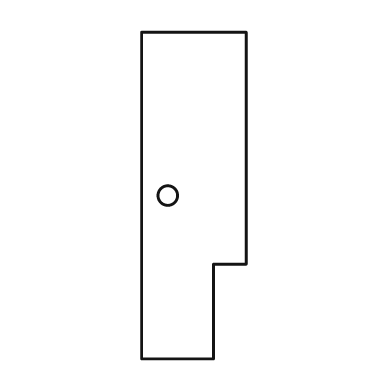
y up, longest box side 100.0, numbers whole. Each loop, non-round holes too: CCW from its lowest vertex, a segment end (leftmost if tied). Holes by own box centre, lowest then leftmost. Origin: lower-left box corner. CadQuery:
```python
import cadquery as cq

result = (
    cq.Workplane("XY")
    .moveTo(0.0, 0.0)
    .lineTo(22.0, 0.0)
    .lineTo(22.0, 29.0)
    .lineTo(32.0, 29.0)
    .lineTo(32.0, 100.0)
    .lineTo(0.0, 100.0)
    .close()
    .moveTo(8.0, 50.0)
    .circle(3.0)
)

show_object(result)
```